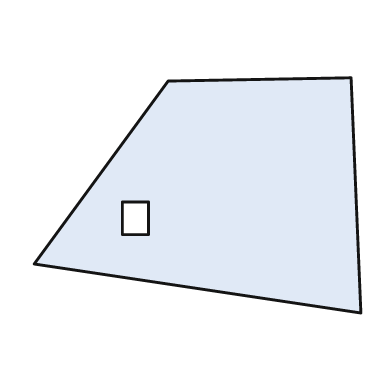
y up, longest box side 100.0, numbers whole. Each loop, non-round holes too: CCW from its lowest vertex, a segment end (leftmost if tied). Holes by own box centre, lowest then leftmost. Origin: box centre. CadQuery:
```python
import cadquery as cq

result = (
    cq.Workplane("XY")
    .moveTo(50.0, -36.0)
    .lineTo(47.0, 36.0)
    .lineTo(-9.0, 35.0)
    .lineTo(-50.0, -21.0)
    .close()
    .moveTo(-23.0, -12.0)
    .lineTo(-15.0, -12.0)
    .lineTo(-15.0, -2.0)
    .lineTo(-23.0, -2.0)
    .close()
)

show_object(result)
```